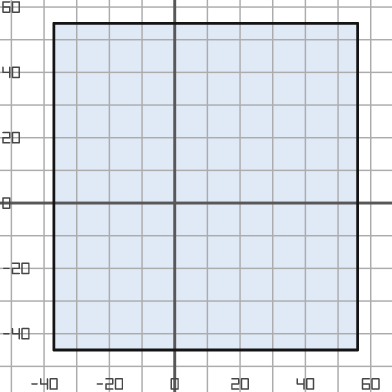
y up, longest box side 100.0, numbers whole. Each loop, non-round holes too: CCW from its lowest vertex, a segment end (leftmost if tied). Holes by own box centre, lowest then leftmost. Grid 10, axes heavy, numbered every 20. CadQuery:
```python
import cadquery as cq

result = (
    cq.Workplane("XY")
    .moveTo(-37.0, -45.0)
    .lineTo(56.0, -45.0)
    .lineTo(56.0, 55.0)
    .lineTo(-37.0, 55.0)
    .close()
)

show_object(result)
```